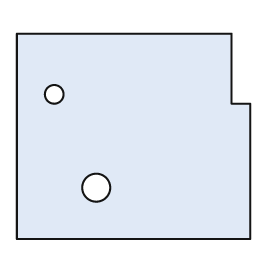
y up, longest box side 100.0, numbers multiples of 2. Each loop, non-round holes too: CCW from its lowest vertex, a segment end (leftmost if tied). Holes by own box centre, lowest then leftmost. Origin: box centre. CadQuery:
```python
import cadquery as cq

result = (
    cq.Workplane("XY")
    .moveTo(-50.0, -44.0)
    .lineTo(50.0, -44.0)
    .lineTo(50.0, 14.0)
    .lineTo(42.0, 14.0)
    .lineTo(42.0, 44.0)
    .lineTo(-50.0, 44.0)
    .close()
    .moveTo(-16.0, -22.0)
    .circle(6.0)
    .moveTo(-34.0, 18.0)
    .circle(4.0)
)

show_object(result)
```